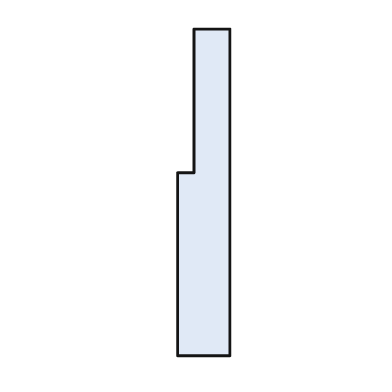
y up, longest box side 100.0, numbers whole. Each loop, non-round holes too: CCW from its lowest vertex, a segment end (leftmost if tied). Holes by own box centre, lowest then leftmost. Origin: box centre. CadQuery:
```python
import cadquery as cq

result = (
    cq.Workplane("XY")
    .moveTo(-8.0, -50.0)
    .lineTo(8.0, -50.0)
    .lineTo(8.0, 50.0)
    .lineTo(-3.0, 50.0)
    .lineTo(-3.0, 6.0)
    .lineTo(-8.0, 6.0)
    .close()
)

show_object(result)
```